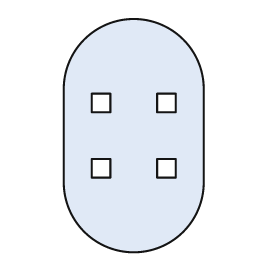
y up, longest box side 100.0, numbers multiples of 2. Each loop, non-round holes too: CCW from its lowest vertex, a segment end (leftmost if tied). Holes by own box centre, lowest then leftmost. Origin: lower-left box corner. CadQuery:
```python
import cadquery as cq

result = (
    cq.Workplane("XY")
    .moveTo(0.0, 30.0)
    .threePointArc((30.0, 0.0), (60.0, 30.0))
    .lineTo(60.0, 70.0)
    .threePointArc((30.0, 100.0), (0.0, 70.0))
    .close()
    .moveTo(12.0, 32.0)
    .lineTo(20.0, 32.0)
    .lineTo(20.0, 40.0)
    .lineTo(12.0, 40.0)
    .close()
    .moveTo(40.0, 32.0)
    .lineTo(48.0, 32.0)
    .lineTo(48.0, 40.0)
    .lineTo(40.0, 40.0)
    .close()
    .moveTo(12.0, 60.0)
    .lineTo(20.0, 60.0)
    .lineTo(20.0, 68.0)
    .lineTo(12.0, 68.0)
    .close()
    .moveTo(40.0, 60.0)
    .lineTo(48.0, 60.0)
    .lineTo(48.0, 68.0)
    .lineTo(40.0, 68.0)
    .close()
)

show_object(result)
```